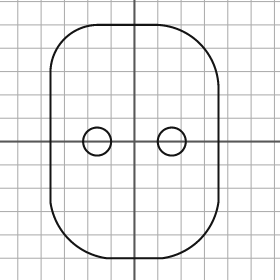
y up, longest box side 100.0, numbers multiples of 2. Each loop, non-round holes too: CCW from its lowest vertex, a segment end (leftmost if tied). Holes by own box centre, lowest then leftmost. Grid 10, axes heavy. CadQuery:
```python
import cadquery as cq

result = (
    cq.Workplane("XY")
    .moveTo(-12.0, -50.0)
    .lineTo(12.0, -50.0)
    .threePointArc((28.0, -42.0), (36.0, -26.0))
    .lineTo(36.0, 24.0)
    .threePointArc((28.0, 42.0), (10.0, 50.0))
    .lineTo(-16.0, 50.0)
    .threePointArc((-30.0, 44.0), (-36.0, 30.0))
    .lineTo(-36.0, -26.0)
    .threePointArc((-28.0, -42.0), (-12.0, -50.0))
    .close()
    .moveTo(-16.0, 0.0)
    .circle(6.0)
    .moveTo(16.0, 0.0)
    .circle(6.0)
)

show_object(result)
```